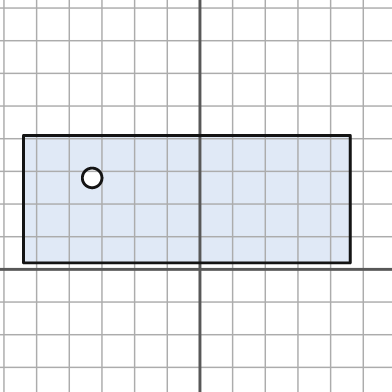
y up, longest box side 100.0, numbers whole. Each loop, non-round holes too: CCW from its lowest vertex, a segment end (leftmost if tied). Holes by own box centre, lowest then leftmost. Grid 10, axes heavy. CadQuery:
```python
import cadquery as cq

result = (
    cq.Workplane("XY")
    .moveTo(-54.0, 2.0)
    .lineTo(46.0, 2.0)
    .lineTo(46.0, 41.0)
    .lineTo(-54.0, 41.0)
    .close()
    .moveTo(-33.0, 28.0)
    .circle(3.0)
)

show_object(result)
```